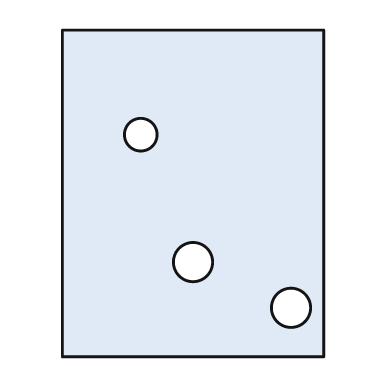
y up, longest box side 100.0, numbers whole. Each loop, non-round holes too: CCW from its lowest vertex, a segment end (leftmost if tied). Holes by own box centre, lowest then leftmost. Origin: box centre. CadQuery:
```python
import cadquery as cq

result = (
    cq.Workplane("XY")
    .moveTo(-40.0, -50.0)
    .lineTo(40.0, -50.0)
    .lineTo(40.0, 50.0)
    .lineTo(-40.0, 50.0)
    .close()
    .moveTo(30.0, -35.0)
    .circle(6.0)
    .moveTo(0.0, -21.0)
    .circle(6.0)
    .moveTo(-16.0, 18.0)
    .circle(5.0)
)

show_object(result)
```